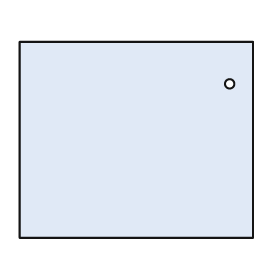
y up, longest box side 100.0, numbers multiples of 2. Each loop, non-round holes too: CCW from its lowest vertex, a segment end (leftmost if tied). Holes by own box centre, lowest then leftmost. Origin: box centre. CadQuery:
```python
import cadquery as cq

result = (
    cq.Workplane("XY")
    .moveTo(-50.0, -42.0)
    .lineTo(50.0, -42.0)
    .lineTo(50.0, 42.0)
    .lineTo(-50.0, 42.0)
    .close()
    .moveTo(40.0, 24.0)
    .circle(2.0)
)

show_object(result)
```